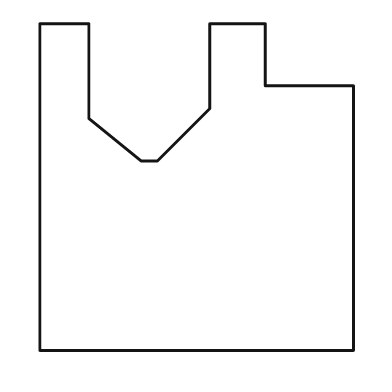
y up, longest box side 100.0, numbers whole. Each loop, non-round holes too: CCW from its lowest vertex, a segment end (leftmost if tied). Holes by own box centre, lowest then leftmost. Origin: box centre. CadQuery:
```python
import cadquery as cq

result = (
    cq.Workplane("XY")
    .moveTo(-48.0, -50.0)
    .lineTo(48.0, -50.0)
    .lineTo(48.0, 31.0)
    .lineTo(21.0, 31.0)
    .lineTo(21.0, 50.0)
    .lineTo(4.0, 50.0)
    .lineTo(4.0, 24.0)
    .lineTo(-12.0, 8.0)
    .lineTo(-17.0, 8.0)
    .lineTo(-33.0, 21.0)
    .lineTo(-33.0, 50.0)
    .lineTo(-48.0, 50.0)
    .close()
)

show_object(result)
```